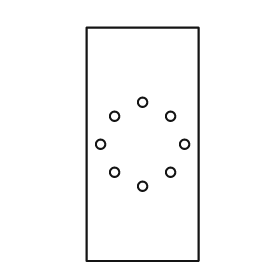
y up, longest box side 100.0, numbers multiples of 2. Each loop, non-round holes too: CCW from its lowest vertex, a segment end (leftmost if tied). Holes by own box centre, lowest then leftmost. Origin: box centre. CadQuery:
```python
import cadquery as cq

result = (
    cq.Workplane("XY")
    .moveTo(-24.0, -50.0)
    .lineTo(24.0, -50.0)
    .lineTo(24.0, 50.0)
    .lineTo(-24.0, 50.0)
    .close()
    .moveTo(0.0, -18.0)
    .circle(2.0)
    .moveTo(-12.0, -12.0)
    .circle(2.0)
    .moveTo(12.0, -12.0)
    .circle(2.0)
    .moveTo(-18.0, 0.0)
    .circle(2.0)
    .moveTo(18.0, 0.0)
    .circle(2.0)
    .moveTo(-12.0, 12.0)
    .circle(2.0)
    .moveTo(12.0, 12.0)
    .circle(2.0)
    .moveTo(0.0, 18.0)
    .circle(2.0)
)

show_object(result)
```